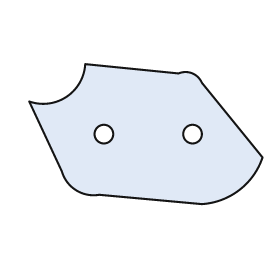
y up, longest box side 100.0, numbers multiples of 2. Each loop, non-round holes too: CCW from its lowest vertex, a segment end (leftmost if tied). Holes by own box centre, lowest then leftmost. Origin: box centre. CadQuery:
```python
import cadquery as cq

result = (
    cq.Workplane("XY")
    .moveTo(24.0, -30.0)
    .threePointArc((40.0, -24.0), (50.0, -10.0))
    .lineTo(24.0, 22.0)
    .threePointArc((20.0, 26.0), (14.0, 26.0))
    .lineTo(-26.0, 30.0)
    .threePointArc((-34.0, 16.0), (-50.0, 14.0))
    .lineTo(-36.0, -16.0)
    .threePointArc((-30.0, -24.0), (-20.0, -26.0))
    .close()
    .moveTo(-18.0, 0.0)
    .circle(4.0)
    .moveTo(20.0, 0.0)
    .circle(4.0)
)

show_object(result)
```